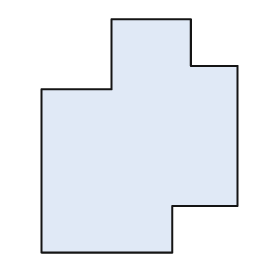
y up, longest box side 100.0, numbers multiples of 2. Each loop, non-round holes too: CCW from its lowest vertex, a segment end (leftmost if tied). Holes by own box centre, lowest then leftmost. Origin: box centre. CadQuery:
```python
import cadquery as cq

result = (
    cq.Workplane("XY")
    .moveTo(-42.0, -50.0)
    .lineTo(14.0, -50.0)
    .lineTo(14.0, -30.0)
    .lineTo(42.0, -30.0)
    .lineTo(42.0, 30.0)
    .lineTo(22.0, 30.0)
    .lineTo(22.0, 50.0)
    .lineTo(-12.0, 50.0)
    .lineTo(-12.0, 20.0)
    .lineTo(-42.0, 20.0)
    .close()
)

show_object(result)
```